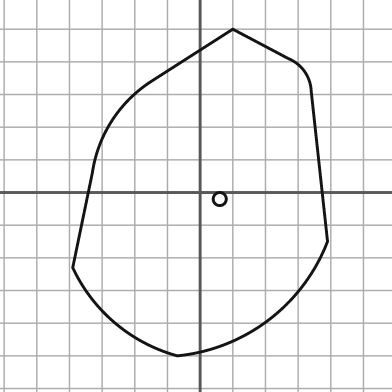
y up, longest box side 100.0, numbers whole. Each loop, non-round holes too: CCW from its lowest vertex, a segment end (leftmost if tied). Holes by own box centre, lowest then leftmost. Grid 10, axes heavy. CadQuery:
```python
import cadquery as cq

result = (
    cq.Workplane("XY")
    .moveTo(-7.0, -50.0)
    .threePointArc((21.0, -39.0), (39.0, -15.0))
    .lineTo(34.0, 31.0)
    .threePointArc((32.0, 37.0), (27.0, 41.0))
    .lineTo(10.0, 50.0)
    .lineTo(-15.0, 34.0)
    .threePointArc((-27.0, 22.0), (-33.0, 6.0))
    .lineTo(-39.0, -23.0)
    .threePointArc((-26.0, -40.0), (-7.0, -50.0))
    .close()
    .moveTo(6.0, -2.0)
    .circle(2.0)
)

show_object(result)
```